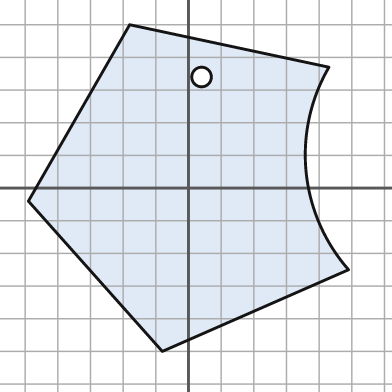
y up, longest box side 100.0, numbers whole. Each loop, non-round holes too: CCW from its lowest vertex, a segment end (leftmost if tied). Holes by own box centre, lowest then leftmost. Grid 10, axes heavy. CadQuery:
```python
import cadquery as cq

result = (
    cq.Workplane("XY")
    .moveTo(-8.0, -50.0)
    .lineTo(49.0, -25.0)
    .threePointArc((36.0, 5.0), (43.0, 37.0))
    .lineTo(-18.0, 50.0)
    .lineTo(-49.0, -4.0)
    .close()
    .moveTo(4.0, 34.0)
    .circle(3.0)
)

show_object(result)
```